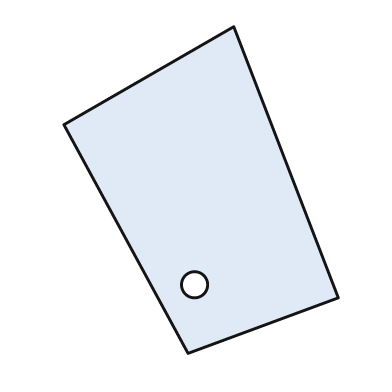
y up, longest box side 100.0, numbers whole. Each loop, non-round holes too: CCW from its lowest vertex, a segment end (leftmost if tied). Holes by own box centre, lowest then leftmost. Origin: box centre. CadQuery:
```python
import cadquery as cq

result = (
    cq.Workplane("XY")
    .moveTo(-4.0, -50.0)
    .lineTo(42.0, -33.0)
    .lineTo(10.0, 50.0)
    .lineTo(-42.0, 20.0)
    .close()
    .moveTo(-2.0, -29.0)
    .circle(4.0)
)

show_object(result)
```